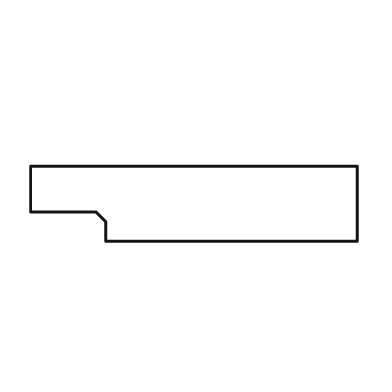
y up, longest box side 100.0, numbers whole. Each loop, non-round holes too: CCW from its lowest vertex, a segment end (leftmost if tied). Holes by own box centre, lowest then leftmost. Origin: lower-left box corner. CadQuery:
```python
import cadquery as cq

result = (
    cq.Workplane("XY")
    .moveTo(23.0, 0.0)
    .lineTo(100.0, 0.0)
    .lineTo(100.0, 23.0)
    .lineTo(0.0, 23.0)
    .lineTo(0.0, 9.0)
    .lineTo(20.0, 9.0)
    .lineTo(23.0, 6.0)
    .close()
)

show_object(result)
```